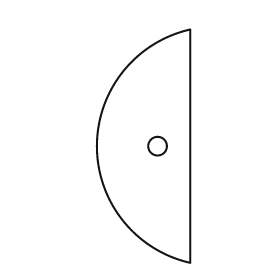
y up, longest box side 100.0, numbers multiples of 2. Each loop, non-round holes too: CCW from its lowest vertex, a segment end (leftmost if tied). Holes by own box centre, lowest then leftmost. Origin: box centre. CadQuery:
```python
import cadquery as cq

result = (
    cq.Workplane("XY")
    .moveTo(20.0, -50.0)
    .lineTo(20.0, 50.0)
    .threePointArc((-20.0, 0.0), (20.0, -50.0))
    .close()
    .moveTo(6.0, 0.0)
    .circle(4.0)
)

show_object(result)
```